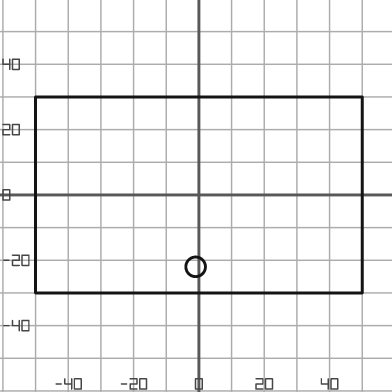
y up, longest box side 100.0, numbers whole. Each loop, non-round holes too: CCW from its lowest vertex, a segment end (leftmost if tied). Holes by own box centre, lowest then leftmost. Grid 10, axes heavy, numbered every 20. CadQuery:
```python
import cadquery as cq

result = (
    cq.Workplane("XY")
    .moveTo(-50.0, -30.0)
    .lineTo(50.0, -30.0)
    .lineTo(50.0, 30.0)
    .lineTo(-50.0, 30.0)
    .close()
    .moveTo(-1.0, -22.0)
    .circle(3.0)
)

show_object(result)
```